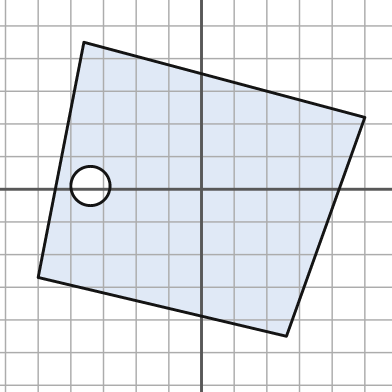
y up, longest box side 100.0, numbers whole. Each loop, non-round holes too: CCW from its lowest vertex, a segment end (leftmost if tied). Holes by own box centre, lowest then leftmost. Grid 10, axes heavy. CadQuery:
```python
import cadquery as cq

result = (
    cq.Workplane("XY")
    .moveTo(26.0, -45.0)
    .lineTo(50.0, 22.0)
    .lineTo(-36.0, 45.0)
    .lineTo(-50.0, -27.0)
    .close()
    .moveTo(-34.0, 1.0)
    .circle(6.0)
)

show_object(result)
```